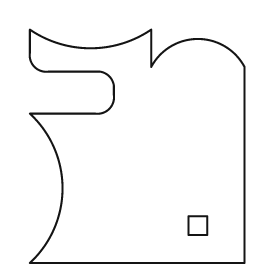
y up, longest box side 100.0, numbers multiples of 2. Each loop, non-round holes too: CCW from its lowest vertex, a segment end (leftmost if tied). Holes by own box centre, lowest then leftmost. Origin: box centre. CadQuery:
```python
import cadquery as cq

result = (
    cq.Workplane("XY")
    .moveTo(-46.0, -50.0)
    .lineTo(46.0, -50.0)
    .lineTo(46.0, 34.0)
    .threePointArc((26.0, 46.0), (6.0, 34.0))
    .lineTo(6.0, 50.0)
    .threePointArc((-20.0, 42.0), (-46.0, 50.0))
    .lineTo(-46.0, 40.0)
    .threePointArc((-44.0, 34.0), (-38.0, 32.0))
    .lineTo(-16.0, 32.0)
    .threePointArc((-12.0, 30.0), (-10.0, 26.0))
    .lineTo(-10.0, 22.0)
    .threePointArc((-12.0, 16.0), (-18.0, 14.0))
    .lineTo(-46.0, 14.0)
    .threePointArc((-32.0, -18.0), (-46.0, -50.0))
    .close()
    .moveTo(22.0, -38.0)
    .lineTo(30.0, -38.0)
    .lineTo(30.0, -30.0)
    .lineTo(22.0, -30.0)
    .close()
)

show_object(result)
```